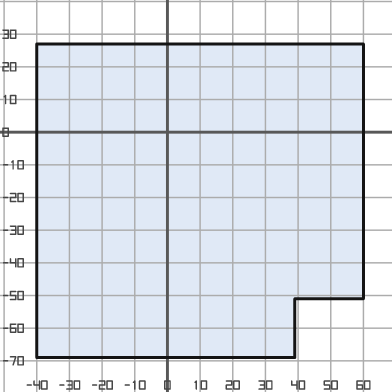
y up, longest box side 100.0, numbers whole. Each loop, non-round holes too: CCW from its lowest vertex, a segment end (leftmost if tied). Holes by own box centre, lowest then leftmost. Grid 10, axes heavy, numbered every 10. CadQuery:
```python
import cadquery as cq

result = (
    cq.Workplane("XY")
    .moveTo(-40.0, -69.0)
    .lineTo(39.0, -69.0)
    .lineTo(39.0, -51.0)
    .lineTo(60.0, -51.0)
    .lineTo(60.0, 27.0)
    .lineTo(-40.0, 27.0)
    .close()
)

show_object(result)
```